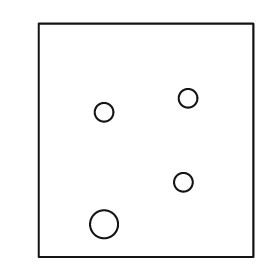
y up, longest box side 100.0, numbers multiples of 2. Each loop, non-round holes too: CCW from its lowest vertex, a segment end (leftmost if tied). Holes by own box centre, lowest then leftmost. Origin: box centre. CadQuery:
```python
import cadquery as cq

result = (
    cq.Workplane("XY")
    .moveTo(-46.0, -50.0)
    .lineTo(46.0, -50.0)
    .lineTo(46.0, 50.0)
    .lineTo(-46.0, 50.0)
    .close()
    .moveTo(-18.0, -36.0)
    .circle(6.0)
    .moveTo(16.0, -18.0)
    .circle(4.0)
    .moveTo(-18.0, 12.0)
    .circle(4.0)
    .moveTo(18.0, 18.0)
    .circle(4.0)
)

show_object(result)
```